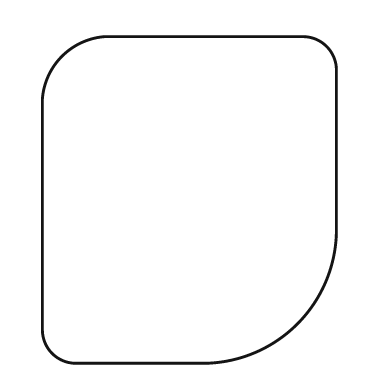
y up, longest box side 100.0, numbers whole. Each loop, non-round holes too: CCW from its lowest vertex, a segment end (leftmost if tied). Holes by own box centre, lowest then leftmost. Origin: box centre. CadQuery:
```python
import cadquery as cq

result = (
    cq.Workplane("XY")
    .moveTo(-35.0, -50.0)
    .lineTo(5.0, -50.0)
    .threePointArc((33.0, -38.0), (45.0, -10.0))
    .lineTo(45.0, 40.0)
    .threePointArc((42.0, 47.0), (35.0, 50.0))
    .lineTo(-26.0, 50.0)
    .threePointArc((-39.0, 44.0), (-45.0, 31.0))
    .lineTo(-45.0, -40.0)
    .threePointArc((-42.0, -47.0), (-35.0, -50.0))
    .close()
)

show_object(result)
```